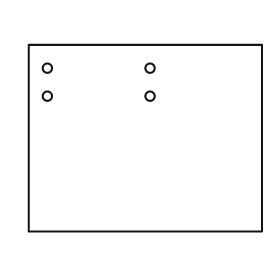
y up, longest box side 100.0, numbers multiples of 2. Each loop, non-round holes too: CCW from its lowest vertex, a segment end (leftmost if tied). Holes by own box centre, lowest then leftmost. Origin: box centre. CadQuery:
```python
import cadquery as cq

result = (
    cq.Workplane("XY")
    .moveTo(-50.0, -40.0)
    .lineTo(50.0, -40.0)
    .lineTo(50.0, 40.0)
    .lineTo(-50.0, 40.0)
    .close()
    .moveTo(-42.0, 18.0)
    .circle(2.0)
    .moveTo(2.0, 18.0)
    .circle(2.0)
    .moveTo(-42.0, 30.0)
    .circle(2.0)
    .moveTo(2.0, 30.0)
    .circle(2.0)
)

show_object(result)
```